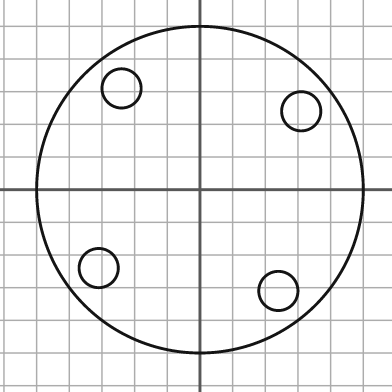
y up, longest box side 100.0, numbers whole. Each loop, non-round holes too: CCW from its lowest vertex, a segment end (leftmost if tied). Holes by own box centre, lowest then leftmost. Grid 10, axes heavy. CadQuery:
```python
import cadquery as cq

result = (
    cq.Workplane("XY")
    .moveTo(0.0, 0.0)
    .circle(50.0)
    .moveTo(24.0, -31.0)
    .circle(6.0)
    .moveTo(-31.0, -24.0)
    .circle(6.0)
    .moveTo(31.0, 24.0)
    .circle(6.0)
    .moveTo(-24.0, 31.0)
    .circle(6.0)
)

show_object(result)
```